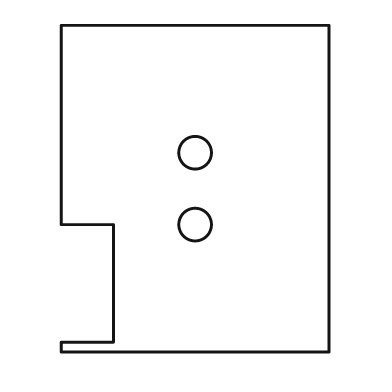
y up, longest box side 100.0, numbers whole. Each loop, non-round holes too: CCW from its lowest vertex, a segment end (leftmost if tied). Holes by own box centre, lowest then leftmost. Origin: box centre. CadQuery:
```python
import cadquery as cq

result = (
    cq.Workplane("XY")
    .moveTo(-41.0, -50.0)
    .lineTo(41.0, -50.0)
    .lineTo(41.0, 50.0)
    .lineTo(-41.0, 50.0)
    .lineTo(-41.0, -11.0)
    .lineTo(-25.0, -11.0)
    .lineTo(-25.0, -47.0)
    .lineTo(-41.0, -47.0)
    .close()
    .moveTo(0.0, -11.0)
    .circle(5.0)
    .moveTo(0.0, 11.0)
    .circle(5.0)
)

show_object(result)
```